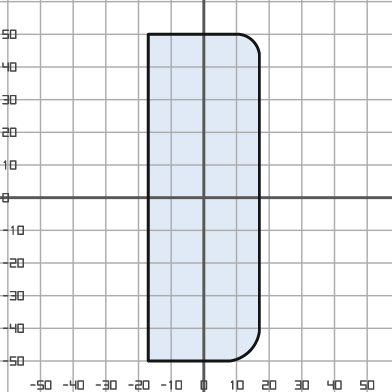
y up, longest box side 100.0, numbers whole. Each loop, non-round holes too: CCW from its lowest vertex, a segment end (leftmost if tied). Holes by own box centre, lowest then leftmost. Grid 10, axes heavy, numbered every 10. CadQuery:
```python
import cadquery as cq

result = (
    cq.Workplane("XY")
    .moveTo(-17.0, -50.0)
    .lineTo(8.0, -50.0)
    .threePointArc((14.0, -47.0), (17.0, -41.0))
    .lineTo(17.0, 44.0)
    .threePointArc((15.0, 48.0), (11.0, 50.0))
    .lineTo(-17.0, 50.0)
    .close()
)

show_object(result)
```